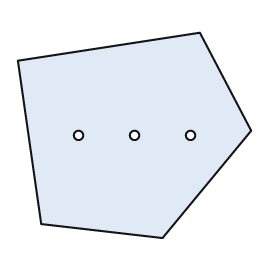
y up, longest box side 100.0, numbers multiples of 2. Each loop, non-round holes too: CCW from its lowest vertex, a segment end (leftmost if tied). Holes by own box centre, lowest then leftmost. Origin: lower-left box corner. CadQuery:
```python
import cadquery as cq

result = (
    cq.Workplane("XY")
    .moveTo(62.0, 0.0)
    .lineTo(100.0, 46.0)
    .lineTo(78.0, 88.0)
    .lineTo(0.0, 76.0)
    .lineTo(10.0, 6.0)
    .close()
    .moveTo(26.0, 44.0)
    .circle(2.0)
    .moveTo(50.0, 44.0)
    .circle(2.0)
    .moveTo(74.0, 44.0)
    .circle(2.0)
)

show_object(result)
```